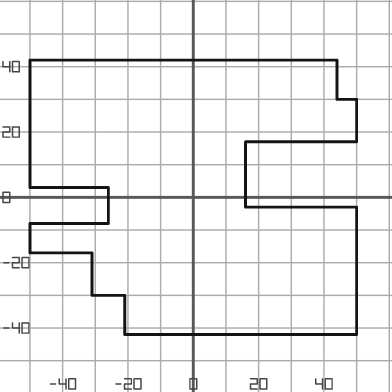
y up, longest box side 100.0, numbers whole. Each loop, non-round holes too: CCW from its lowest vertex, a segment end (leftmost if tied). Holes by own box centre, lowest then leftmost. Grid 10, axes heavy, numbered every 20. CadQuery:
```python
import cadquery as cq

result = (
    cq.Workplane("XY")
    .moveTo(-21.0, -42.0)
    .lineTo(50.0, -42.0)
    .lineTo(50.0, -3.0)
    .lineTo(16.0, -3.0)
    .lineTo(16.0, 17.0)
    .lineTo(50.0, 17.0)
    .lineTo(50.0, 30.0)
    .lineTo(44.0, 30.0)
    .lineTo(44.0, 42.0)
    .lineTo(-50.0, 42.0)
    .lineTo(-50.0, 3.0)
    .lineTo(-26.0, 3.0)
    .lineTo(-26.0, -8.0)
    .lineTo(-50.0, -8.0)
    .lineTo(-50.0, -17.0)
    .lineTo(-31.0, -17.0)
    .lineTo(-31.0, -30.0)
    .lineTo(-21.0, -30.0)
    .close()
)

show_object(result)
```